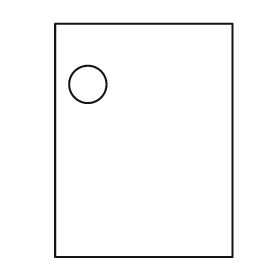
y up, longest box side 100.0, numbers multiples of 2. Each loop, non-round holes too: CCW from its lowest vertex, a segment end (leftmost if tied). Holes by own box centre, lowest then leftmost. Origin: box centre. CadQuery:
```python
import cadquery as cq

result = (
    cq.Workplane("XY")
    .moveTo(-38.0, -50.0)
    .lineTo(38.0, -50.0)
    .lineTo(38.0, 50.0)
    .lineTo(-38.0, 50.0)
    .close()
    .moveTo(-24.0, 24.0)
    .circle(8.0)
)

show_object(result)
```